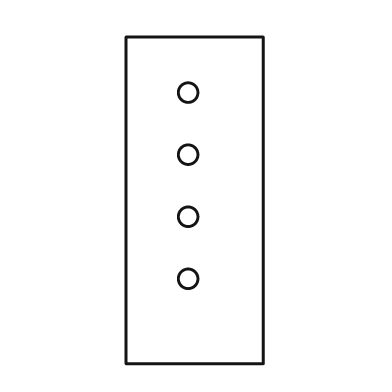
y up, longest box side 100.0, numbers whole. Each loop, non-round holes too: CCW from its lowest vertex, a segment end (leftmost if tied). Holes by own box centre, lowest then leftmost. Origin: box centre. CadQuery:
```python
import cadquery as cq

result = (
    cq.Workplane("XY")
    .moveTo(-21.0, -50.0)
    .lineTo(21.0, -50.0)
    .lineTo(21.0, 50.0)
    .lineTo(-21.0, 50.0)
    .close()
    .moveTo(-2.0, -24.0)
    .circle(3.0)
    .moveTo(-2.0, -5.0)
    .circle(3.0)
    .moveTo(-2.0, 14.0)
    .circle(3.0)
    .moveTo(-2.0, 33.0)
    .circle(3.0)
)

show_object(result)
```